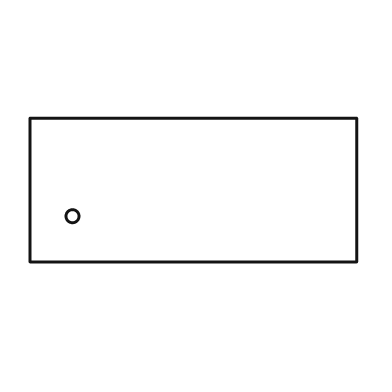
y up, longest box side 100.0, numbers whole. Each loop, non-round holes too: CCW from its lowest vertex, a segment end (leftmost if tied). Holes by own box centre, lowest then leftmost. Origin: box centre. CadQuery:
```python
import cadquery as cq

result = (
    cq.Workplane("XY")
    .moveTo(-50.0, -22.0)
    .lineTo(50.0, -22.0)
    .lineTo(50.0, 22.0)
    .lineTo(-50.0, 22.0)
    .close()
    .moveTo(-37.0, -8.0)
    .circle(2.0)
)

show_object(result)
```